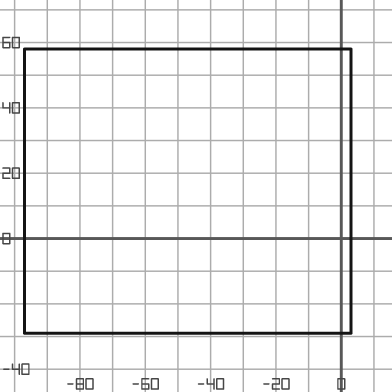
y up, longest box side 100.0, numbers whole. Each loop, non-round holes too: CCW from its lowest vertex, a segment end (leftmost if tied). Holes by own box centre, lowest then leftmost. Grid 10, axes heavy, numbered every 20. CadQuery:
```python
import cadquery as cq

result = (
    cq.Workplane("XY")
    .moveTo(-97.0, -29.0)
    .lineTo(3.0, -29.0)
    .lineTo(3.0, 58.0)
    .lineTo(-97.0, 58.0)
    .close()
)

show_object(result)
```